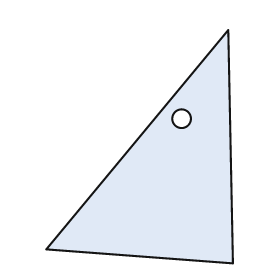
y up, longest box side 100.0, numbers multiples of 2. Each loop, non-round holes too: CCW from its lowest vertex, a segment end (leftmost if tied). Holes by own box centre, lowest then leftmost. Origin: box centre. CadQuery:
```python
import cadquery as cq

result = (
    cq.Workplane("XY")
    .moveTo(40.0, -50.0)
    .lineTo(38.0, 50.0)
    .lineTo(-40.0, -44.0)
    .close()
    .moveTo(18.0, 12.0)
    .circle(4.0)
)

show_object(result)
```